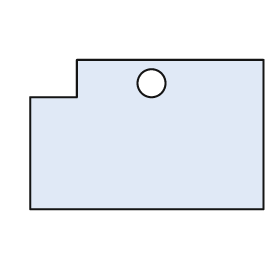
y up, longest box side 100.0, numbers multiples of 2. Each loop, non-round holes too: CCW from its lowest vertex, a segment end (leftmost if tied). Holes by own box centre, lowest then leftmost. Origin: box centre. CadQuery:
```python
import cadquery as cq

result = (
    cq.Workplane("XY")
    .moveTo(-50.0, -32.0)
    .lineTo(50.0, -32.0)
    .lineTo(50.0, 32.0)
    .lineTo(-30.0, 32.0)
    .lineTo(-30.0, 16.0)
    .lineTo(-50.0, 16.0)
    .close()
    .moveTo(2.0, 22.0)
    .circle(6.0)
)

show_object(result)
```